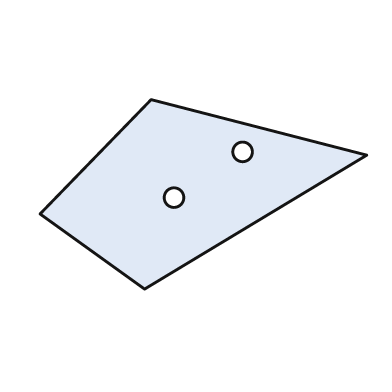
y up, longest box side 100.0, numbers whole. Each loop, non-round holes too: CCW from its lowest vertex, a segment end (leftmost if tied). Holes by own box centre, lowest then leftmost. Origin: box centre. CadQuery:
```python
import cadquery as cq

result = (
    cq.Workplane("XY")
    .moveTo(-18.0, -29.0)
    .lineTo(50.0, 12.0)
    .lineTo(-16.0, 29.0)
    .lineTo(-50.0, -6.0)
    .close()
    .moveTo(-9.0, -1.0)
    .circle(3.0)
    .moveTo(12.0, 13.0)
    .circle(3.0)
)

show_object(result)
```